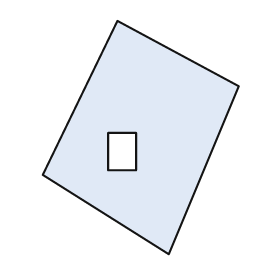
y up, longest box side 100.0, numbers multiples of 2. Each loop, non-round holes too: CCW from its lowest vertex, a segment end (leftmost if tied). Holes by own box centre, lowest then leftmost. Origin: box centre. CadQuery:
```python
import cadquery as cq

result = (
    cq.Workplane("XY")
    .moveTo(12.0, -50.0)
    .lineTo(42.0, 22.0)
    .lineTo(-10.0, 50.0)
    .lineTo(-42.0, -16.0)
    .close()
    .moveTo(-14.0, -14.0)
    .lineTo(-2.0, -14.0)
    .lineTo(-2.0, 2.0)
    .lineTo(-14.0, 2.0)
    .close()
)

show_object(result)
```